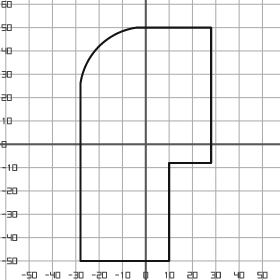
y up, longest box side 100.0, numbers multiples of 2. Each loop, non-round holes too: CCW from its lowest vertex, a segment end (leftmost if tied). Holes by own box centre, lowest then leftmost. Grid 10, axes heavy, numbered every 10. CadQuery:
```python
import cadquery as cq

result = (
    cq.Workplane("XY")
    .moveTo(-28.0, -50.0)
    .lineTo(10.0, -50.0)
    .lineTo(10.0, -8.0)
    .lineTo(28.0, -8.0)
    .lineTo(28.0, 50.0)
    .lineTo(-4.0, 50.0)
    .threePointArc((-20.0, 42.0), (-28.0, 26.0))
    .close()
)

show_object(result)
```